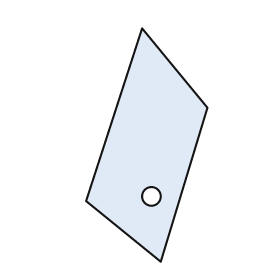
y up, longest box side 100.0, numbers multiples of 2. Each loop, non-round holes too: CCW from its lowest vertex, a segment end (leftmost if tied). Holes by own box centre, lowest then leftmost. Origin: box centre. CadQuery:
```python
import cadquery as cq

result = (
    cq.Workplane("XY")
    .moveTo(6.0, -50.0)
    .lineTo(26.0, 16.0)
    .lineTo(-2.0, 50.0)
    .lineTo(-26.0, -24.0)
    .close()
    .moveTo(2.0, -22.0)
    .circle(4.0)
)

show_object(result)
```